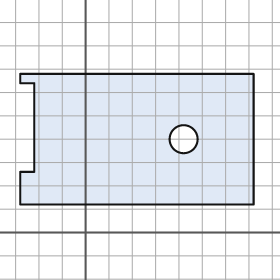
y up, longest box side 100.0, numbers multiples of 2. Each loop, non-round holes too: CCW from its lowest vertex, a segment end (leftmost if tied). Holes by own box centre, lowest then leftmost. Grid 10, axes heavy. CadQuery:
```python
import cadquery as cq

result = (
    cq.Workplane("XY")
    .moveTo(-28.0, 12.0)
    .lineTo(72.0, 12.0)
    .lineTo(72.0, 68.0)
    .lineTo(-28.0, 68.0)
    .lineTo(-28.0, 64.0)
    .lineTo(-22.0, 64.0)
    .lineTo(-22.0, 26.0)
    .lineTo(-28.0, 26.0)
    .close()
    .moveTo(42.0, 40.0)
    .circle(6.0)
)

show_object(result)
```